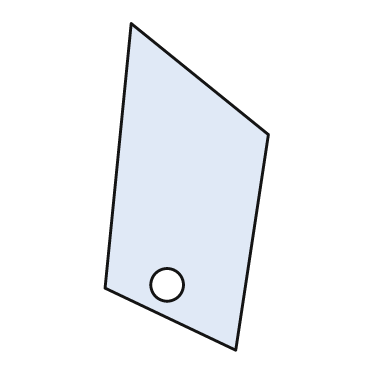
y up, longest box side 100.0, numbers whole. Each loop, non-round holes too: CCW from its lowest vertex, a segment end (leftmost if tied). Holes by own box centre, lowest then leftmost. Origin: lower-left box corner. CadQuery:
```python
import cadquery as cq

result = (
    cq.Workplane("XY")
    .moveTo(40.0, 0.0)
    .lineTo(50.0, 66.0)
    .lineTo(8.0, 100.0)
    .lineTo(0.0, 19.0)
    .close()
    .moveTo(19.0, 20.0)
    .circle(5.0)
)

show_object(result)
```